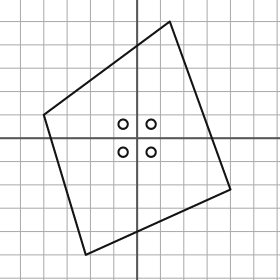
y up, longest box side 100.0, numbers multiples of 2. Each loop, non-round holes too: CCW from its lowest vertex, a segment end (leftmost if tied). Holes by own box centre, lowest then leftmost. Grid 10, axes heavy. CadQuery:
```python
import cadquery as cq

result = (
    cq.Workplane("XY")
    .moveTo(-22.0, -50.0)
    .lineTo(40.0, -22.0)
    .lineTo(14.0, 50.0)
    .lineTo(-40.0, 10.0)
    .close()
    .moveTo(-6.0, -6.0)
    .circle(2.0)
    .moveTo(6.0, -6.0)
    .circle(2.0)
    .moveTo(-6.0, 6.0)
    .circle(2.0)
    .moveTo(6.0, 6.0)
    .circle(2.0)
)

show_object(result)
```